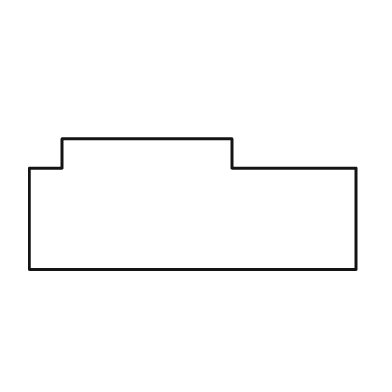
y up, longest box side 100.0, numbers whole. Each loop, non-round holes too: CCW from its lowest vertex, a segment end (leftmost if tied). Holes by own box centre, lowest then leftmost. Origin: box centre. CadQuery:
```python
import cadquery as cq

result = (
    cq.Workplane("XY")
    .moveTo(-50.0, -20.0)
    .lineTo(50.0, -20.0)
    .lineTo(50.0, 11.0)
    .lineTo(12.0, 11.0)
    .lineTo(12.0, 20.0)
    .lineTo(-40.0, 20.0)
    .lineTo(-40.0, 11.0)
    .lineTo(-50.0, 11.0)
    .close()
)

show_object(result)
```